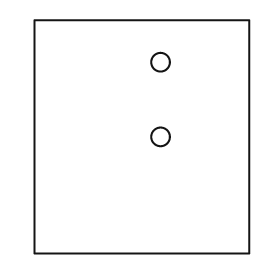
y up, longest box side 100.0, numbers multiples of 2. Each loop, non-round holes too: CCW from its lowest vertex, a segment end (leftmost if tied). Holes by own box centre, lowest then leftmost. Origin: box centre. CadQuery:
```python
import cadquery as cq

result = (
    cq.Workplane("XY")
    .moveTo(-46.0, -50.0)
    .lineTo(46.0, -50.0)
    .lineTo(46.0, 50.0)
    .lineTo(-46.0, 50.0)
    .close()
    .moveTo(8.0, 0.0)
    .circle(4.0)
    .moveTo(8.0, 32.0)
    .circle(4.0)
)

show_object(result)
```